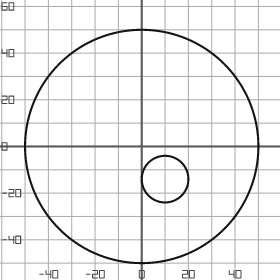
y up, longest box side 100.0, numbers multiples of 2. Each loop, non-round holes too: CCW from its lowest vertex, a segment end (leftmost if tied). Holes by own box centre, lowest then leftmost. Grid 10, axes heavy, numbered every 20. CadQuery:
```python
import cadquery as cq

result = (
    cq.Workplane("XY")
    .moveTo(0.0, 0.0)
    .circle(50.0)
    .moveTo(10.0, -14.0)
    .circle(10.0)
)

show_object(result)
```